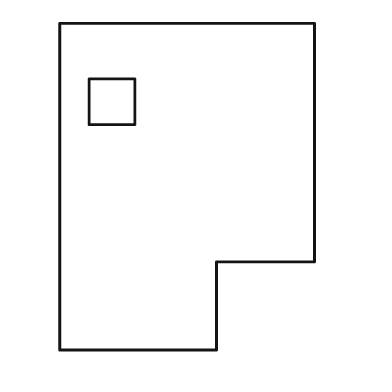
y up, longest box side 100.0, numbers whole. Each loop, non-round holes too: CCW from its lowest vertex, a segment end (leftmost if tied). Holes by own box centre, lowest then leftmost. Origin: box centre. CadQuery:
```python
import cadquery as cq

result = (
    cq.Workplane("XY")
    .moveTo(-39.0, -50.0)
    .lineTo(9.0, -50.0)
    .lineTo(9.0, -23.0)
    .lineTo(39.0, -23.0)
    .lineTo(39.0, 50.0)
    .lineTo(-39.0, 50.0)
    .close()
    .moveTo(-30.0, 19.0)
    .lineTo(-16.0, 19.0)
    .lineTo(-16.0, 33.0)
    .lineTo(-30.0, 33.0)
    .close()
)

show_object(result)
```